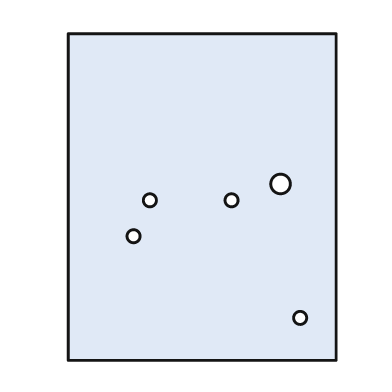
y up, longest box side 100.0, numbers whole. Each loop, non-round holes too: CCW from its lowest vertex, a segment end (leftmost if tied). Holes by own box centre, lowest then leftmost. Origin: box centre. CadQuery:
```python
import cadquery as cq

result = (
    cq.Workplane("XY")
    .moveTo(-41.0, -50.0)
    .lineTo(41.0, -50.0)
    .lineTo(41.0, 50.0)
    .lineTo(-41.0, 50.0)
    .close()
    .moveTo(30.0, -37.0)
    .circle(2.0)
    .moveTo(-21.0, -12.0)
    .circle(2.0)
    .moveTo(-16.0, -1.0)
    .circle(2.0)
    .moveTo(9.0, -1.0)
    .circle(2.0)
    .moveTo(24.0, 4.0)
    .circle(3.0)
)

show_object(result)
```